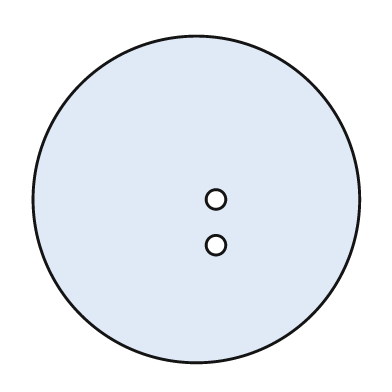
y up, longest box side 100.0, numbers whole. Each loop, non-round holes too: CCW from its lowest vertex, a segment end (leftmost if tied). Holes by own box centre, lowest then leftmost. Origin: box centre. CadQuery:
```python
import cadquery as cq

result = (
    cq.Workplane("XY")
    .moveTo(0.0, 0.0)
    .circle(50.0)
    .moveTo(6.0, -14.0)
    .circle(3.0)
    .moveTo(6.0, 0.0)
    .circle(3.0)
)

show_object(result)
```